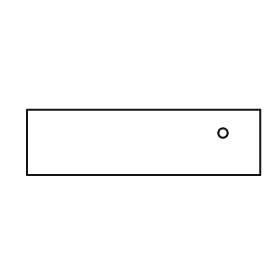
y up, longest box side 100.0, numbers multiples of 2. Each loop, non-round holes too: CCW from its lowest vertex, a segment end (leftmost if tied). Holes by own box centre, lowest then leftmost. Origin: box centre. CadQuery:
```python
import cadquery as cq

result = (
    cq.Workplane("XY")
    .moveTo(-50.0, -14.0)
    .lineTo(50.0, -14.0)
    .lineTo(50.0, 14.0)
    .lineTo(-50.0, 14.0)
    .close()
    .moveTo(34.0, 4.0)
    .circle(2.0)
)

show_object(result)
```